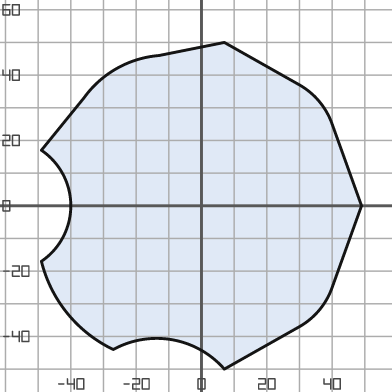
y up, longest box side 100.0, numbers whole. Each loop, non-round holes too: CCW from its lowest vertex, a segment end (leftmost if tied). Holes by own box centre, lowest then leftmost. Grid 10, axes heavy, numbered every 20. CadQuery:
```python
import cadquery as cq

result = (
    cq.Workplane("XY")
    .moveTo(7.0, -50.0)
    .lineTo(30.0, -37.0)
    .threePointArc((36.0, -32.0), (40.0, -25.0))
    .lineTo(49.0, 0.0)
    .lineTo(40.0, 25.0)
    .threePointArc((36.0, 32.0), (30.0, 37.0))
    .lineTo(7.0, 50.0)
    .lineTo(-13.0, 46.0)
    .threePointArc((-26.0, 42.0), (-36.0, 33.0))
    .lineTo(-49.0, 17.0)
    .threePointArc((-40.0, 0.0), (-49.0, -17.0))
    .threePointArc((-41.0, -33.0), (-27.0, -44.0))
    .threePointArc((-9.0, -41.0), (7.0, -50.0))
    .close()
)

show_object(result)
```